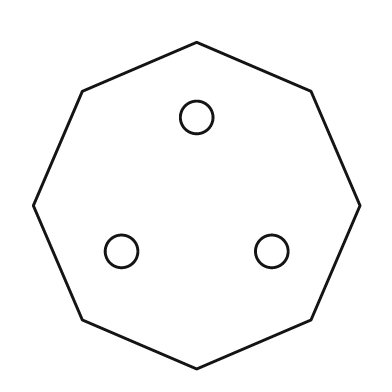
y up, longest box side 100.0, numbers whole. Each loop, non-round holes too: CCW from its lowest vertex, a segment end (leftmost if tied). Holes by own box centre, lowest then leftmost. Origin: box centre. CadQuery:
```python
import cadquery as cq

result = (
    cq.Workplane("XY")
    .moveTo(0.0, -50.0)
    .lineTo(35.0, -35.0)
    .lineTo(50.0, 0.0)
    .lineTo(35.0, 35.0)
    .lineTo(0.0, 50.0)
    .lineTo(-35.0, 35.0)
    .lineTo(-50.0, 0.0)
    .lineTo(-35.0, -35.0)
    .close()
    .moveTo(-23.0, -14.0)
    .circle(5.0)
    .moveTo(23.0, -14.0)
    .circle(5.0)
    .moveTo(0.0, 27.0)
    .circle(5.0)
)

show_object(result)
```